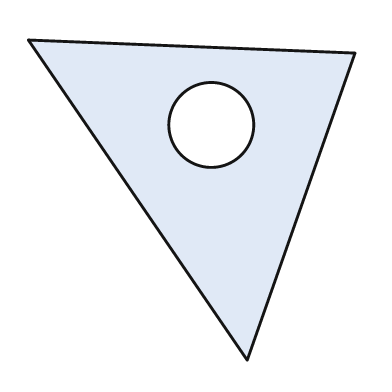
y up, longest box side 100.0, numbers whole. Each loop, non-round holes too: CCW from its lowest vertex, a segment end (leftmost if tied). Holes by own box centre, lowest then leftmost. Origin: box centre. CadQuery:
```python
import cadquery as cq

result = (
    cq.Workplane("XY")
    .moveTo(17.0, -49.0)
    .lineTo(50.0, 45.0)
    .lineTo(-50.0, 49.0)
    .close()
    .moveTo(6.0, 23.0)
    .circle(13.0)
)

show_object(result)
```